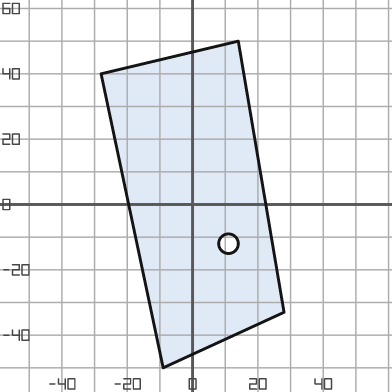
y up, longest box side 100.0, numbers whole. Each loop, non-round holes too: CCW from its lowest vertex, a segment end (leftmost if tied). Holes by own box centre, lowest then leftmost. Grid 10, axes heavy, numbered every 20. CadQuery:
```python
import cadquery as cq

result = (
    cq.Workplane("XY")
    .moveTo(-9.0, -50.0)
    .lineTo(28.0, -33.0)
    .lineTo(14.0, 50.0)
    .lineTo(-28.0, 40.0)
    .close()
    .moveTo(11.0, -12.0)
    .circle(3.0)
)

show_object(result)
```